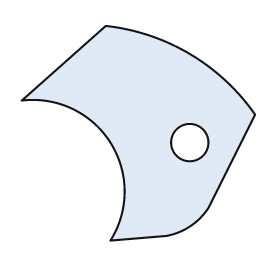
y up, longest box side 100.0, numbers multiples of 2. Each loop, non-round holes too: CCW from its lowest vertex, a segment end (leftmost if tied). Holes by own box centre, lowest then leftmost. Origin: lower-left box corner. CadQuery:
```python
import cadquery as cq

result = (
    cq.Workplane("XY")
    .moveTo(38.0, 0.0)
    .lineTo(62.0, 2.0)
    .threePointArc((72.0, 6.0), (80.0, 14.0))
    .lineTo(100.0, 54.0)
    .threePointArc((72.0, 80.0), (36.0, 92.0))
    .lineTo(0.0, 60.0)
    .threePointArc((38.0, 42.0), (38.0, 0.0))
    .close()
    .moveTo(72.0, 42.0)
    .circle(8.0)
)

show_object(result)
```